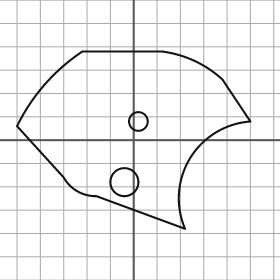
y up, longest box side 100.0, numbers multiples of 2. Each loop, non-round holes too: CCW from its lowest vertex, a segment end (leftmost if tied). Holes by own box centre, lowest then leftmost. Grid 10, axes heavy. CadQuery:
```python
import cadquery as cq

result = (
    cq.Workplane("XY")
    .moveTo(22.0, -38.0)
    .threePointArc((24.0, -8.0), (50.0, 8.0))
    .lineTo(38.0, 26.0)
    .threePointArc((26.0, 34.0), (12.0, 38.0))
    .lineTo(-22.0, 38.0)
    .threePointArc((-38.0, 24.0), (-50.0, 6.0))
    .lineTo(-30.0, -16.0)
    .threePointArc((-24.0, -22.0), (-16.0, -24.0))
    .close()
    .moveTo(-4.0, -18.0)
    .circle(6.0)
    .moveTo(2.0, 8.0)
    .circle(4.0)
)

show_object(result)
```